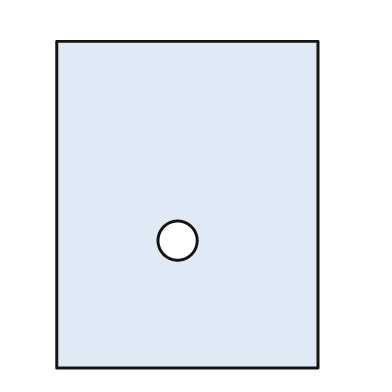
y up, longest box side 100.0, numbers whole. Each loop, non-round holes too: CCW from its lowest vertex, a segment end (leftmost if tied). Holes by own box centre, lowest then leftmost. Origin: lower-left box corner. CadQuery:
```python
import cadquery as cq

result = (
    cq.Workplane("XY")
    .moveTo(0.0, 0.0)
    .lineTo(80.0, 0.0)
    .lineTo(80.0, 100.0)
    .lineTo(0.0, 100.0)
    .close()
    .moveTo(37.0, 39.0)
    .circle(6.0)
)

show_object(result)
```